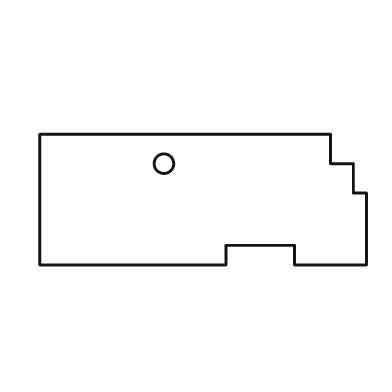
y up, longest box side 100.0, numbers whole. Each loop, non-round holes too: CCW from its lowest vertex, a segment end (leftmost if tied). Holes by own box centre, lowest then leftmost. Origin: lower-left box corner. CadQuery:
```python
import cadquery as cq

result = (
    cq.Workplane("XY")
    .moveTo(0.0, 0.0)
    .lineTo(57.0, 0.0)
    .lineTo(57.0, 6.0)
    .lineTo(78.0, 6.0)
    .lineTo(78.0, 0.0)
    .lineTo(100.0, 0.0)
    .lineTo(100.0, 22.0)
    .lineTo(96.0, 22.0)
    .lineTo(96.0, 31.0)
    .lineTo(89.0, 31.0)
    .lineTo(89.0, 40.0)
    .lineTo(0.0, 40.0)
    .close()
    .moveTo(38.0, 31.0)
    .circle(3.0)
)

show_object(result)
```